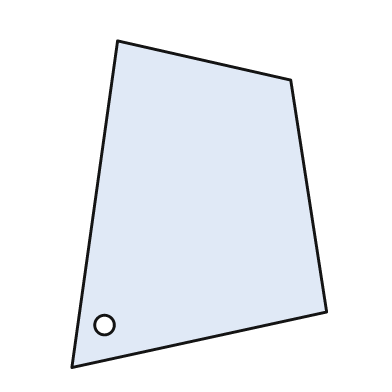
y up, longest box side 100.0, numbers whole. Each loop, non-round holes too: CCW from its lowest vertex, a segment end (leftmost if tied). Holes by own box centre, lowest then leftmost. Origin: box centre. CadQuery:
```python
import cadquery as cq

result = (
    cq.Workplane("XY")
    .moveTo(-39.0, -50.0)
    .lineTo(39.0, -33.0)
    .lineTo(28.0, 38.0)
    .lineTo(-25.0, 50.0)
    .close()
    .moveTo(-29.0, -37.0)
    .circle(3.0)
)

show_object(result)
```